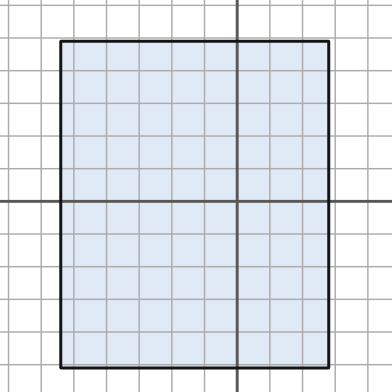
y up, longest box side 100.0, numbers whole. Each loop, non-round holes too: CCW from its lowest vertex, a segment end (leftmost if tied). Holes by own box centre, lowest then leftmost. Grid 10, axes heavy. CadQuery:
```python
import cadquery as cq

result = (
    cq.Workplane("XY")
    .moveTo(-54.0, -51.0)
    .lineTo(28.0, -51.0)
    .lineTo(28.0, 49.0)
    .lineTo(-54.0, 49.0)
    .close()
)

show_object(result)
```